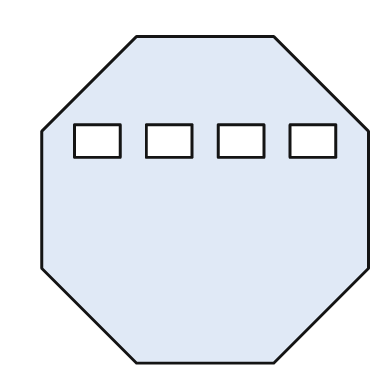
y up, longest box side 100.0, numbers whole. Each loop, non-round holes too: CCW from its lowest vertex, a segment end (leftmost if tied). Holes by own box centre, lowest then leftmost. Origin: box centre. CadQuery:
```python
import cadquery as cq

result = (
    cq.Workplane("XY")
    .moveTo(-21.0, -50.0)
    .lineTo(21.0, -50.0)
    .lineTo(50.0, -21.0)
    .lineTo(50.0, 21.0)
    .lineTo(21.0, 50.0)
    .lineTo(-21.0, 50.0)
    .lineTo(-50.0, 21.0)
    .lineTo(-50.0, -21.0)
    .close()
    .moveTo(-40.0, 13.0)
    .lineTo(-26.0, 13.0)
    .lineTo(-26.0, 23.0)
    .lineTo(-40.0, 23.0)
    .close()
    .moveTo(-18.0, 13.0)
    .lineTo(-4.0, 13.0)
    .lineTo(-4.0, 23.0)
    .lineTo(-18.0, 23.0)
    .close()
    .moveTo(4.0, 13.0)
    .lineTo(18.0, 13.0)
    .lineTo(18.0, 23.0)
    .lineTo(4.0, 23.0)
    .close()
    .moveTo(26.0, 13.0)
    .lineTo(40.0, 13.0)
    .lineTo(40.0, 23.0)
    .lineTo(26.0, 23.0)
    .close()
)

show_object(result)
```